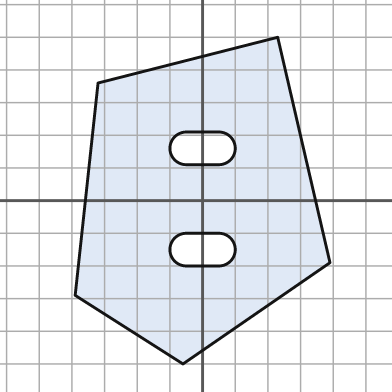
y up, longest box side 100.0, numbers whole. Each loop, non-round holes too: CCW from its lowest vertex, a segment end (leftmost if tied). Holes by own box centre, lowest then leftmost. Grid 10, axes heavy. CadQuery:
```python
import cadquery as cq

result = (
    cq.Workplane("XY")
    .moveTo(-6.0, -50.0)
    .lineTo(39.0, -19.0)
    .lineTo(23.0, 50.0)
    .lineTo(-32.0, 36.0)
    .lineTo(-39.0, -29.0)
    .close()
    .moveTo(-5.0, -20.0)
    .lineTo(5.0, -20.0)
    .threePointArc((10.0, -15.0), (5.0, -10.0))
    .lineTo(-5.0, -10.0)
    .threePointArc((-10.0, -15.0), (-5.0, -20.0))
    .close()
    .moveTo(-5.0, 11.0)
    .lineTo(5.0, 11.0)
    .threePointArc((10.0, 16.0), (5.0, 21.0))
    .lineTo(-5.0, 21.0)
    .threePointArc((-10.0, 16.0), (-5.0, 11.0))
    .close()
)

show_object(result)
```